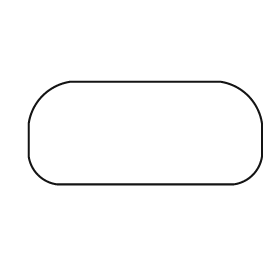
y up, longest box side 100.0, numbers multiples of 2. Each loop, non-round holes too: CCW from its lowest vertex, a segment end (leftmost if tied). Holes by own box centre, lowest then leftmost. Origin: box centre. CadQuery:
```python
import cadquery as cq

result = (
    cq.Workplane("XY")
    .moveTo(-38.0, -22.0)
    .lineTo(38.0, -22.0)
    .threePointArc((46.0, -18.0), (50.0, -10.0))
    .lineTo(50.0, 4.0)
    .threePointArc((44.0, 16.0), (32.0, 22.0))
    .lineTo(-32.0, 22.0)
    .threePointArc((-44.0, 16.0), (-50.0, 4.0))
    .lineTo(-50.0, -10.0)
    .threePointArc((-46.0, -18.0), (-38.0, -22.0))
    .close()
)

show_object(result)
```